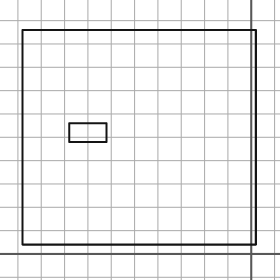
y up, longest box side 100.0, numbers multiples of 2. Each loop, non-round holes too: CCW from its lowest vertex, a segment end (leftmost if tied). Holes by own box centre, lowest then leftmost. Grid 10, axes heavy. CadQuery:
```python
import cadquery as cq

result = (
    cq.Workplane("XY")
    .moveTo(-98.0, 4.0)
    .lineTo(2.0, 4.0)
    .lineTo(2.0, 96.0)
    .lineTo(-98.0, 96.0)
    .close()
    .moveTo(-78.0, 48.0)
    .lineTo(-62.0, 48.0)
    .lineTo(-62.0, 56.0)
    .lineTo(-78.0, 56.0)
    .close()
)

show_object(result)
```